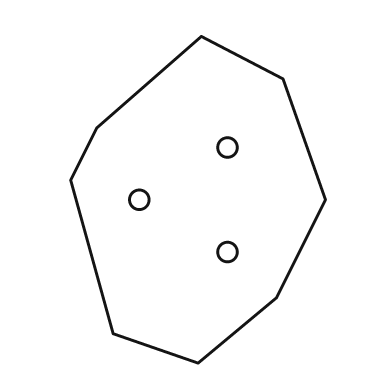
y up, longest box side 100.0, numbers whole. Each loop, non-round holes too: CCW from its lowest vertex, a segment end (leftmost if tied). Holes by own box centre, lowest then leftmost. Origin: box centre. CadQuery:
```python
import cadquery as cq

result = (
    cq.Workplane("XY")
    .moveTo(0.0, -50.0)
    .lineTo(24.0, -30.0)
    .lineTo(39.0, 0.0)
    .lineTo(26.0, 37.0)
    .lineTo(1.0, 50.0)
    .lineTo(-31.0, 22.0)
    .lineTo(-39.0, 6.0)
    .lineTo(-26.0, -41.0)
    .close()
    .moveTo(9.0, -16.0)
    .circle(3.0)
    .moveTo(-18.0, 0.0)
    .circle(3.0)
    .moveTo(9.0, 16.0)
    .circle(3.0)
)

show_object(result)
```